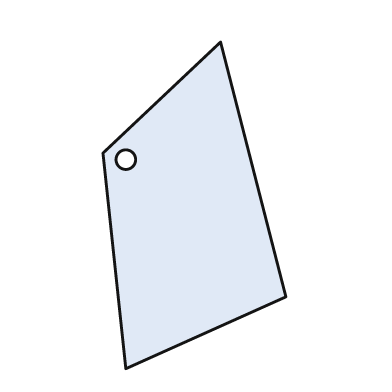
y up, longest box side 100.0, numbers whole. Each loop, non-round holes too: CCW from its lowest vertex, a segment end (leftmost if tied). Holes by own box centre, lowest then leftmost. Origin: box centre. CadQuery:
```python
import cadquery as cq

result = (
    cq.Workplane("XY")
    .moveTo(-21.0, -50.0)
    .lineTo(28.0, -28.0)
    .lineTo(8.0, 50.0)
    .lineTo(-28.0, 16.0)
    .close()
    .moveTo(-21.0, 14.0)
    .circle(3.0)
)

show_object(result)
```